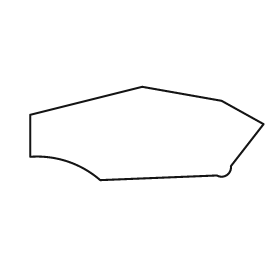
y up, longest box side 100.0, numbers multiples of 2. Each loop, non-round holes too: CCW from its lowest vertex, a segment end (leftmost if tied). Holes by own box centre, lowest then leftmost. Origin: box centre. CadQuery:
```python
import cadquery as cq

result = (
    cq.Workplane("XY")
    .moveTo(-20.0, -20.0)
    .lineTo(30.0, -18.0)
    .threePointArc((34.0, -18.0), (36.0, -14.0))
    .lineTo(50.0, 4.0)
    .lineTo(32.0, 14.0)
    .lineTo(-2.0, 20.0)
    .lineTo(-50.0, 8.0)
    .lineTo(-50.0, -10.0)
    .threePointArc((-34.0, -12.0), (-20.0, -20.0))
    .close()
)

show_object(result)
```